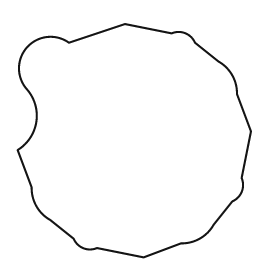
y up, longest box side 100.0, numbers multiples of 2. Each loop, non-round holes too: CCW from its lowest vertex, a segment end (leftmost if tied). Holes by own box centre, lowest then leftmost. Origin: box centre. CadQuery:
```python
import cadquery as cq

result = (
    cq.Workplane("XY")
    .moveTo(4.0, -50.0)
    .lineTo(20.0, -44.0)
    .threePointArc((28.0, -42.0), (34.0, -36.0))
    .lineTo(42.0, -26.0)
    .threePointArc((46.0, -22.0), (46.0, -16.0))
    .lineTo(50.0, 4.0)
    .lineTo(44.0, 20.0)
    .threePointArc((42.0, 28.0), (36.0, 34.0))
    .lineTo(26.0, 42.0)
    .threePointArc((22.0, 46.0), (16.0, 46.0))
    .lineTo(-4.0, 50.0)
    .lineTo(-28.0, 42.0)
    .threePointArc((-46.0, 40.0), (-46.0, 22.0))
    .threePointArc((-42.0, 8.0), (-50.0, -4.0))
    .lineTo(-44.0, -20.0)
    .threePointArc((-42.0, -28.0), (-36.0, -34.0))
    .lineTo(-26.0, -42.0)
    .threePointArc((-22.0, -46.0), (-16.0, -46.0))
    .close()
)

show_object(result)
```